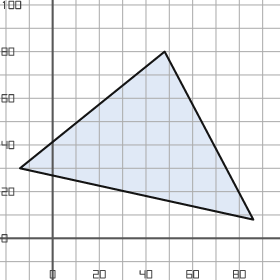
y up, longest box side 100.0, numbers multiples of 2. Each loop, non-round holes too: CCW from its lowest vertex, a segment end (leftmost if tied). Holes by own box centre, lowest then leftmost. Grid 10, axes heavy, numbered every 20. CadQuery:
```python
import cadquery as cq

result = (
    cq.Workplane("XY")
    .moveTo(86.0, 8.0)
    .lineTo(48.0, 80.0)
    .lineTo(-14.0, 30.0)
    .close()
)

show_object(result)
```